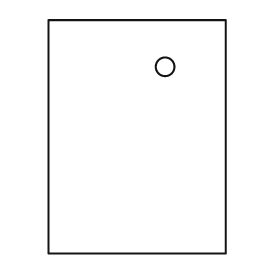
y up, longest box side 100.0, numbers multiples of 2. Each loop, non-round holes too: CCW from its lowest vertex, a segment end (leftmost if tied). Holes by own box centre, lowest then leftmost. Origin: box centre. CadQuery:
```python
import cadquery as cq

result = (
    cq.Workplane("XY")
    .moveTo(-38.0, -50.0)
    .lineTo(38.0, -50.0)
    .lineTo(38.0, 50.0)
    .lineTo(-38.0, 50.0)
    .close()
    .moveTo(12.0, 30.0)
    .circle(4.0)
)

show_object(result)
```